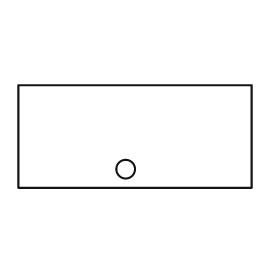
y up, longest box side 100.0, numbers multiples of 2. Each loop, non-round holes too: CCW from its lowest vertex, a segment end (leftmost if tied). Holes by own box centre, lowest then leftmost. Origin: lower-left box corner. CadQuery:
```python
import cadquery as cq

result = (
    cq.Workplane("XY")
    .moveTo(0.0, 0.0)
    .lineTo(100.0, 0.0)
    .lineTo(100.0, 44.0)
    .lineTo(0.0, 44.0)
    .close()
    .moveTo(46.0, 8.0)
    .circle(4.0)
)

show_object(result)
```